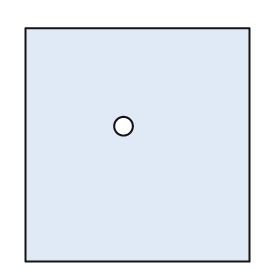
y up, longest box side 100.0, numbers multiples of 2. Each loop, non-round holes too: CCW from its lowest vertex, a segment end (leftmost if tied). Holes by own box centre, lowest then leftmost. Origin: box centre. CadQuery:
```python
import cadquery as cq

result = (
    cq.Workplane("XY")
    .moveTo(-48.0, -50.0)
    .lineTo(48.0, -50.0)
    .lineTo(48.0, 50.0)
    .lineTo(-48.0, 50.0)
    .close()
    .moveTo(-6.0, 8.0)
    .circle(4.0)
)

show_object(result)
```